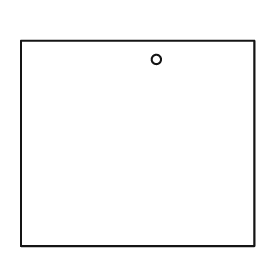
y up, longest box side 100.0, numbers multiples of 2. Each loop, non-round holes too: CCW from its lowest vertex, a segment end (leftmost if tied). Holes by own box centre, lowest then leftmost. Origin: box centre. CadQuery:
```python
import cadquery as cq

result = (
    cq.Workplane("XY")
    .moveTo(-50.0, -44.0)
    .lineTo(50.0, -44.0)
    .lineTo(50.0, 44.0)
    .lineTo(-50.0, 44.0)
    .close()
    .moveTo(8.0, 36.0)
    .circle(2.0)
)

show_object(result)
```